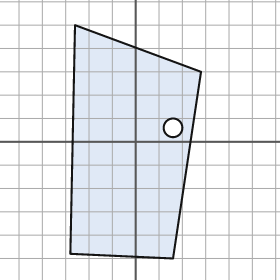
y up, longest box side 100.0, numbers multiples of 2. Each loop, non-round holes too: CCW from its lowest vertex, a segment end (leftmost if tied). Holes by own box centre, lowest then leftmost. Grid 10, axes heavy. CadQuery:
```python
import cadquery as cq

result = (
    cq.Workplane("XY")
    .moveTo(16.0, -50.0)
    .lineTo(28.0, 30.0)
    .lineTo(-26.0, 50.0)
    .lineTo(-28.0, -48.0)
    .close()
    .moveTo(16.0, 6.0)
    .circle(4.0)
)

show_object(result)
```